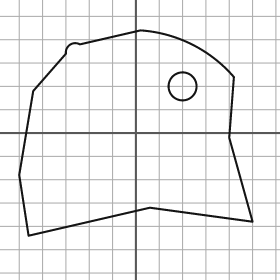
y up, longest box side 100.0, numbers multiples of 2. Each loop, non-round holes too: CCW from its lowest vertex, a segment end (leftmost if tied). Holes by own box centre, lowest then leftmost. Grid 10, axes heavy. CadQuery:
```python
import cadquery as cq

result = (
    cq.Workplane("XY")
    .moveTo(-46.0, -44.0)
    .lineTo(6.0, -32.0)
    .lineTo(50.0, -38.0)
    .lineTo(40.0, -2.0)
    .lineTo(42.0, 24.0)
    .threePointArc((24.0, 38.0), (2.0, 44.0))
    .lineTo(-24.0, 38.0)
    .threePointArc((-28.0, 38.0), (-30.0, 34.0))
    .lineTo(-44.0, 18.0)
    .lineTo(-50.0, -18.0)
    .close()
    .moveTo(20.0, 20.0)
    .circle(6.0)
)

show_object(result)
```